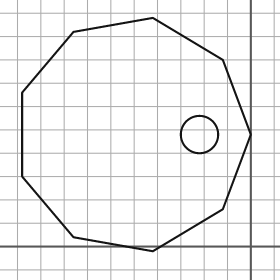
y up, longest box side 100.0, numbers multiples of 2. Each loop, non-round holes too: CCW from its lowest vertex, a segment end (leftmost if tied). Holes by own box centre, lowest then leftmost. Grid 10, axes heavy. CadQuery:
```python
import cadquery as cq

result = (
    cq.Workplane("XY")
    .moveTo(-42.0, -2.0)
    .lineTo(-12.0, 16.0)
    .lineTo(0.0, 48.0)
    .lineTo(-12.0, 80.0)
    .lineTo(-42.0, 98.0)
    .lineTo(-76.0, 92.0)
    .lineTo(-98.0, 66.0)
    .lineTo(-98.0, 30.0)
    .lineTo(-76.0, 4.0)
    .close()
    .moveTo(-22.0, 48.0)
    .circle(8.0)
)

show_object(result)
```